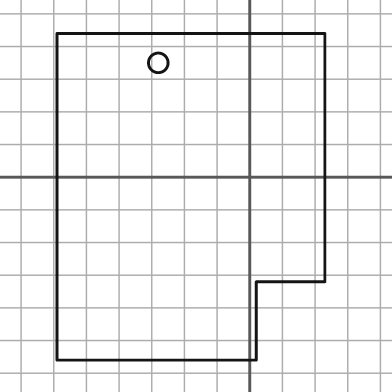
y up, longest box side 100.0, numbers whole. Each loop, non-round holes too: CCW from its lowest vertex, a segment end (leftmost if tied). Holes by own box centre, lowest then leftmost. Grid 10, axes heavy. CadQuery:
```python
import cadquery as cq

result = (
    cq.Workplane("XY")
    .moveTo(-59.0, -56.0)
    .lineTo(2.0, -56.0)
    .lineTo(2.0, -32.0)
    .lineTo(23.0, -32.0)
    .lineTo(23.0, 44.0)
    .lineTo(-59.0, 44.0)
    .close()
    .moveTo(-28.0, 35.0)
    .circle(3.0)
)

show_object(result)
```